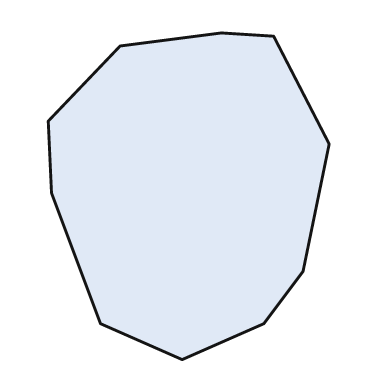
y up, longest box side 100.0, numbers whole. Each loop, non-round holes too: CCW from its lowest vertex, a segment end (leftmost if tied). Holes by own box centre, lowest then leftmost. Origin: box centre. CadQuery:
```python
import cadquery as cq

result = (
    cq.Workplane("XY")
    .moveTo(-2.0, -50.0)
    .lineTo(23.0, -39.0)
    .lineTo(35.0, -23.0)
    .lineTo(43.0, 16.0)
    .lineTo(26.0, 49.0)
    .lineTo(10.0, 50.0)
    .lineTo(-21.0, 46.0)
    .lineTo(-43.0, 23.0)
    .lineTo(-42.0, 1.0)
    .lineTo(-27.0, -39.0)
    .close()
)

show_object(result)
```